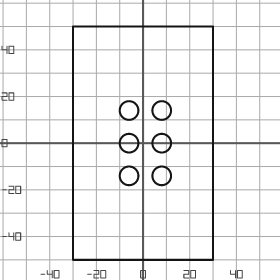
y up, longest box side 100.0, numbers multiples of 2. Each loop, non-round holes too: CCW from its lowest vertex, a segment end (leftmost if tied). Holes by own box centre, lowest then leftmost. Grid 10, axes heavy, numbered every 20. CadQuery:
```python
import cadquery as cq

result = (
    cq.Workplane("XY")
    .moveTo(-30.0, -50.0)
    .lineTo(30.0, -50.0)
    .lineTo(30.0, 50.0)
    .lineTo(-30.0, 50.0)
    .close()
    .moveTo(-6.0, -14.0)
    .circle(4.0)
    .moveTo(8.0, -14.0)
    .circle(4.0)
    .moveTo(-6.0, 0.0)
    .circle(4.0)
    .moveTo(8.0, 0.0)
    .circle(4.0)
    .moveTo(-6.0, 14.0)
    .circle(4.0)
    .moveTo(8.0, 14.0)
    .circle(4.0)
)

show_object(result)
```